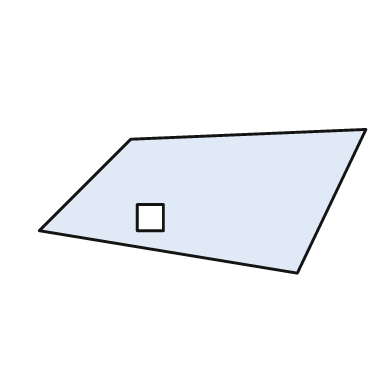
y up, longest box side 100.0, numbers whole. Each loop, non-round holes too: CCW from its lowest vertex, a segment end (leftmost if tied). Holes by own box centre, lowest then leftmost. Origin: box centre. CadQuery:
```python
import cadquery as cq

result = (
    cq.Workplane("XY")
    .moveTo(29.0, -22.0)
    .lineTo(50.0, 22.0)
    .lineTo(-22.0, 19.0)
    .lineTo(-50.0, -9.0)
    .close()
    .moveTo(-20.0, -9.0)
    .lineTo(-12.0, -9.0)
    .lineTo(-12.0, -1.0)
    .lineTo(-20.0, -1.0)
    .close()
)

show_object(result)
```